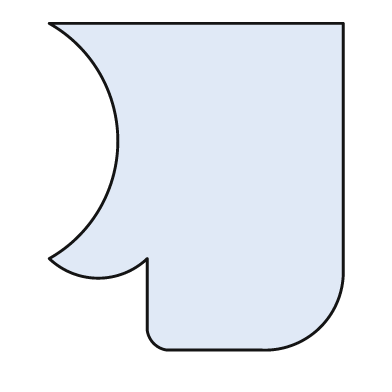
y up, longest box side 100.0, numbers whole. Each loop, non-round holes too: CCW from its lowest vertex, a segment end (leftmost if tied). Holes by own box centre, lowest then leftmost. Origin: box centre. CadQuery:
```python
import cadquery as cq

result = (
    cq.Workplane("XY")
    .moveTo(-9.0, -50.0)
    .lineTo(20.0, -50.0)
    .threePointArc((38.0, -43.0), (45.0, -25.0))
    .lineTo(45.0, 50.0)
    .lineTo(-45.0, 50.0)
    .threePointArc((-24.0, 14.0), (-45.0, -22.0))
    .threePointArc((-30.0, -28.0), (-15.0, -22.0))
    .lineTo(-15.0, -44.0)
    .threePointArc((-13.0, -48.0), (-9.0, -50.0))
    .close()
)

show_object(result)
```